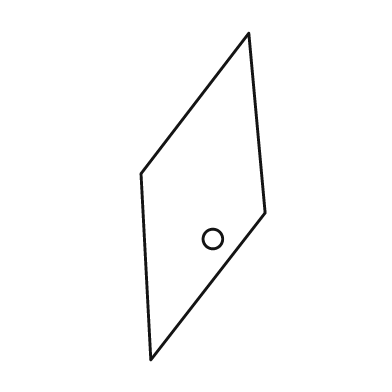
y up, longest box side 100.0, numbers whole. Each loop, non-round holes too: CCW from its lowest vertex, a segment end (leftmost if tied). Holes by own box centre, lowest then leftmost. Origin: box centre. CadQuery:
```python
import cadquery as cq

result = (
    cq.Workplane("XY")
    .moveTo(-16.0, -50.0)
    .lineTo(19.0, -5.0)
    .lineTo(14.0, 50.0)
    .lineTo(-19.0, 7.0)
    .close()
    .moveTo(3.0, -13.0)
    .circle(3.0)
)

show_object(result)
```